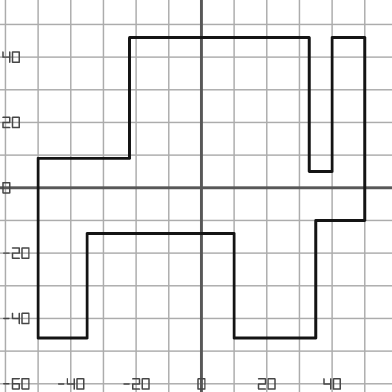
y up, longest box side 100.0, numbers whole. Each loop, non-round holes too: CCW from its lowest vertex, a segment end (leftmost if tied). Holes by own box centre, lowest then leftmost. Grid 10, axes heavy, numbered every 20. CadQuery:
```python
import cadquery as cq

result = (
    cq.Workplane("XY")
    .moveTo(-50.0, -46.0)
    .lineTo(-35.0, -46.0)
    .lineTo(-35.0, -14.0)
    .lineTo(10.0, -14.0)
    .lineTo(10.0, -46.0)
    .lineTo(35.0, -46.0)
    .lineTo(35.0, -10.0)
    .lineTo(50.0, -10.0)
    .lineTo(50.0, 46.0)
    .lineTo(40.0, 46.0)
    .lineTo(40.0, 5.0)
    .lineTo(33.0, 5.0)
    .lineTo(33.0, 46.0)
    .lineTo(-22.0, 46.0)
    .lineTo(-22.0, 9.0)
    .lineTo(-50.0, 9.0)
    .close()
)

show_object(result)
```